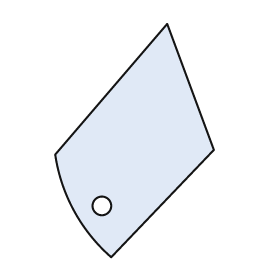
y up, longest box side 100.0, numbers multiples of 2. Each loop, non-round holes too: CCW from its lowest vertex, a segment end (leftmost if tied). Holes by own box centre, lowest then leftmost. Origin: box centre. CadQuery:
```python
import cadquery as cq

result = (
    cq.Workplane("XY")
    .moveTo(-10.0, -50.0)
    .lineTo(34.0, -4.0)
    .lineTo(14.0, 50.0)
    .lineTo(-34.0, -6.0)
    .threePointArc((-26.0, -30.0), (-10.0, -50.0))
    .close()
    .moveTo(-14.0, -28.0)
    .circle(4.0)
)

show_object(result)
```